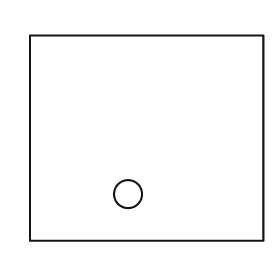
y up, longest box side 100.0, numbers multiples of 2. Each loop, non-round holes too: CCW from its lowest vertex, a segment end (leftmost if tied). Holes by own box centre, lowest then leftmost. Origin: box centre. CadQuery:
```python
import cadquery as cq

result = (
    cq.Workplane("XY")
    .moveTo(-50.0, -44.0)
    .lineTo(50.0, -44.0)
    .lineTo(50.0, 44.0)
    .lineTo(-50.0, 44.0)
    .close()
    .moveTo(-8.0, -24.0)
    .circle(6.0)
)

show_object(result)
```